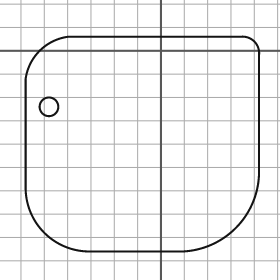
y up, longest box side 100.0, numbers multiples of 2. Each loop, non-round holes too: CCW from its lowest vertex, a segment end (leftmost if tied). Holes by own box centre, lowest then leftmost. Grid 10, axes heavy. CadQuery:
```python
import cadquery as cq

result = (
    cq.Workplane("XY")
    .moveTo(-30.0, -86.0)
    .lineTo(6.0, -86.0)
    .threePointArc((32.0, -76.0), (42.0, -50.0))
    .lineTo(42.0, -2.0)
    .threePointArc((40.0, 4.0), (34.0, 6.0))
    .lineTo(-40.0, 6.0)
    .threePointArc((-52.0, 0.0), (-58.0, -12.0))
    .lineTo(-58.0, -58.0)
    .threePointArc((-50.0, -78.0), (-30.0, -86.0))
    .close()
    .moveTo(-48.0, -24.0)
    .circle(4.0)
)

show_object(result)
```